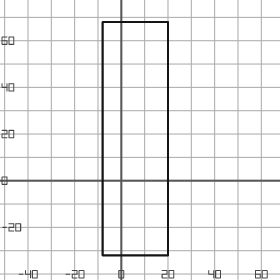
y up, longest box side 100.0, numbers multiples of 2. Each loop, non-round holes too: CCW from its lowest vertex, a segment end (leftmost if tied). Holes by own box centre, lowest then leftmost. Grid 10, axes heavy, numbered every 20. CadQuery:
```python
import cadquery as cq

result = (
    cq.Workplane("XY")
    .moveTo(-8.0, -32.0)
    .lineTo(20.0, -32.0)
    .lineTo(20.0, 68.0)
    .lineTo(-8.0, 68.0)
    .close()
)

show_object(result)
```